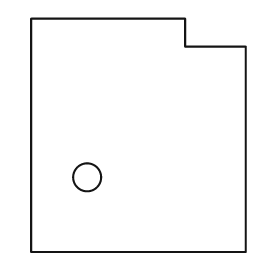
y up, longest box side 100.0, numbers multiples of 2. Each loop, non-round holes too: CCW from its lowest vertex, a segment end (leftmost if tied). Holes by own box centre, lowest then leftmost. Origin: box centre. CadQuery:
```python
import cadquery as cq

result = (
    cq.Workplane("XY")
    .moveTo(-46.0, -50.0)
    .lineTo(46.0, -50.0)
    .lineTo(46.0, 38.0)
    .lineTo(20.0, 38.0)
    .lineTo(20.0, 50.0)
    .lineTo(-46.0, 50.0)
    .close()
    .moveTo(-22.0, -18.0)
    .circle(6.0)
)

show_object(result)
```